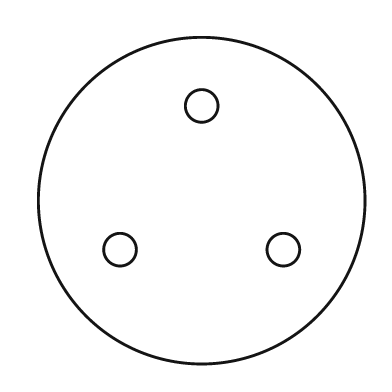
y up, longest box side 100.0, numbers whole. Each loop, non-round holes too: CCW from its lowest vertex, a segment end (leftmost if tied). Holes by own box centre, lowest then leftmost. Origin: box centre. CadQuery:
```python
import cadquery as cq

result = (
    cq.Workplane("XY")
    .moveTo(0.0, 0.0)
    .circle(50.0)
    .moveTo(-25.0, -15.0)
    .circle(5.0)
    .moveTo(25.0, -15.0)
    .circle(5.0)
    .moveTo(0.0, 29.0)
    .circle(5.0)
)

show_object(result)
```